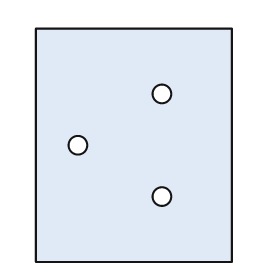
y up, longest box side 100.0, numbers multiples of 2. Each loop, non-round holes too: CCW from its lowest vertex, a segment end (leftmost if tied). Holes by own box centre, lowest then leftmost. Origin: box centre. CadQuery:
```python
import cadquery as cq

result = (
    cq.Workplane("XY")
    .moveTo(-42.0, -50.0)
    .lineTo(42.0, -50.0)
    .lineTo(42.0, 50.0)
    .lineTo(-42.0, 50.0)
    .close()
    .moveTo(12.0, -22.0)
    .circle(4.0)
    .moveTo(-24.0, 0.0)
    .circle(4.0)
    .moveTo(12.0, 22.0)
    .circle(4.0)
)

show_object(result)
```